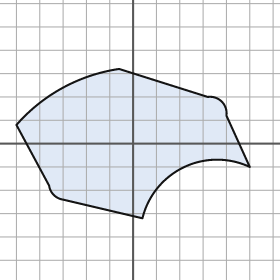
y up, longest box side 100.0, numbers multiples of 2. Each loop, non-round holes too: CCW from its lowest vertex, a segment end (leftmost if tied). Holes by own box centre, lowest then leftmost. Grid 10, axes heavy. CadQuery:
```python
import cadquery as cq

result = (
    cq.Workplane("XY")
    .moveTo(4.0, -32.0)
    .threePointArc((22.0, -10.0), (50.0, -10.0))
    .lineTo(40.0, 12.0)
    .threePointArc((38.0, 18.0), (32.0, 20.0))
    .lineTo(-6.0, 32.0)
    .threePointArc((-30.0, 24.0), (-50.0, 8.0))
    .lineTo(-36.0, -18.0)
    .threePointArc((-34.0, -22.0), (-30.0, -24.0))
    .close()
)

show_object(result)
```